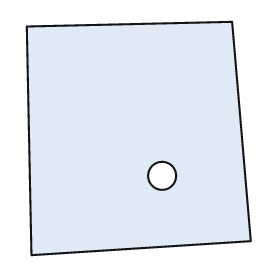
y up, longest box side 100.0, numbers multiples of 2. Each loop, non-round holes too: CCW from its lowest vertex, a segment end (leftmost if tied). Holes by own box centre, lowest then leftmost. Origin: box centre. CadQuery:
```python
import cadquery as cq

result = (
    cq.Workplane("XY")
    .moveTo(-46.0, -50.0)
    .lineTo(48.0, -44.0)
    .lineTo(40.0, 50.0)
    .lineTo(-48.0, 48.0)
    .close()
    .moveTo(10.0, -16.0)
    .circle(6.0)
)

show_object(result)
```